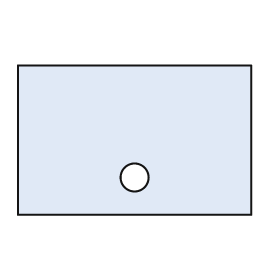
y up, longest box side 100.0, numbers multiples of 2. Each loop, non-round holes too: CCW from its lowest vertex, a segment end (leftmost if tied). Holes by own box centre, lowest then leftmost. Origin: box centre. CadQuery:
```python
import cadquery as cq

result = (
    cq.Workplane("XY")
    .moveTo(-50.0, -32.0)
    .lineTo(50.0, -32.0)
    .lineTo(50.0, 32.0)
    .lineTo(-50.0, 32.0)
    .close()
    .moveTo(0.0, -16.0)
    .circle(6.0)
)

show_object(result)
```